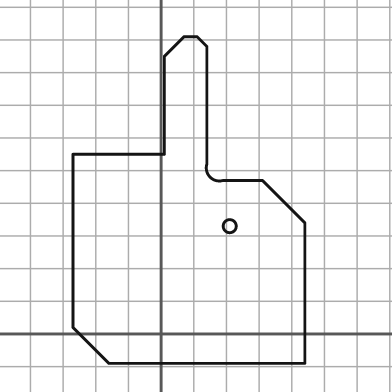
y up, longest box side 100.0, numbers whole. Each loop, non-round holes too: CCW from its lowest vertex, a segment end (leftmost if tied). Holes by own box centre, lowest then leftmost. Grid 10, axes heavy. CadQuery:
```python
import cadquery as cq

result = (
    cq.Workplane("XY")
    .moveTo(-16.0, -9.0)
    .lineTo(44.0, -9.0)
    .lineTo(44.0, 34.0)
    .lineTo(31.0, 47.0)
    .lineTo(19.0, 47.0)
    .threePointArc((15.0, 48.0), (14.0, 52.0))
    .lineTo(14.0, 88.0)
    .lineTo(11.0, 91.0)
    .lineTo(7.0, 91.0)
    .lineTo(1.0, 85.0)
    .lineTo(1.0, 55.0)
    .lineTo(-27.0, 55.0)
    .lineTo(-27.0, 2.0)
    .close()
    .moveTo(21.0, 33.0)
    .circle(2.0)
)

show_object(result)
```